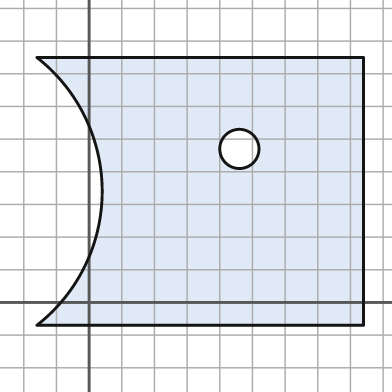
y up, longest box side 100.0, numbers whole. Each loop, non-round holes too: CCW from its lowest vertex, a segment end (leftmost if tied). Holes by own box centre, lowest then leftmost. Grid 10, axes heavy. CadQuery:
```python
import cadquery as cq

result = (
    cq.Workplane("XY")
    .moveTo(-16.0, -7.0)
    .lineTo(84.0, -7.0)
    .lineTo(84.0, 75.0)
    .lineTo(-16.0, 75.0)
    .threePointArc((4.0, 34.0), (-16.0, -7.0))
    .close()
    .moveTo(46.0, 47.0)
    .circle(6.0)
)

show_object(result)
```